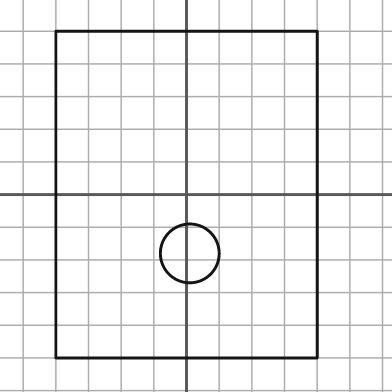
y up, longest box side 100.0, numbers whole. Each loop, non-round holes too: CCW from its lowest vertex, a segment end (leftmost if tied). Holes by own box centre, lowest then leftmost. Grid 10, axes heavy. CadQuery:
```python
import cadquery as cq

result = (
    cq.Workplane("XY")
    .moveTo(-40.0, -50.0)
    .lineTo(40.0, -50.0)
    .lineTo(40.0, 50.0)
    .lineTo(-40.0, 50.0)
    .close()
    .moveTo(1.0, -18.0)
    .circle(9.0)
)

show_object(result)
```